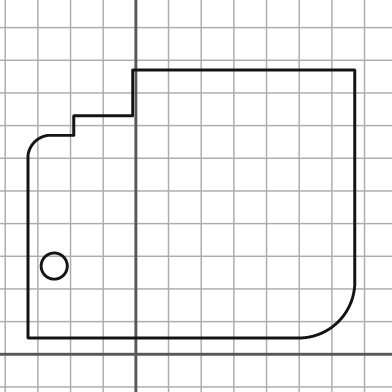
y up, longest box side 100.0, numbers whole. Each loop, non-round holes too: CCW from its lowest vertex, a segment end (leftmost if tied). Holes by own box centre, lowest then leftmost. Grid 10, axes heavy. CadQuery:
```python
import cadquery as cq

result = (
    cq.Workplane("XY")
    .moveTo(-33.0, 5.0)
    .lineTo(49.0, 5.0)
    .threePointArc((62.0, 10.0), (67.0, 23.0))
    .lineTo(67.0, 87.0)
    .lineTo(-1.0, 87.0)
    .lineTo(-1.0, 73.0)
    .lineTo(-19.0, 73.0)
    .lineTo(-19.0, 67.0)
    .lineTo(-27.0, 67.0)
    .threePointArc((-31.0, 65.0), (-33.0, 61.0))
    .close()
    .moveTo(-25.0, 27.0)
    .circle(4.0)
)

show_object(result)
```